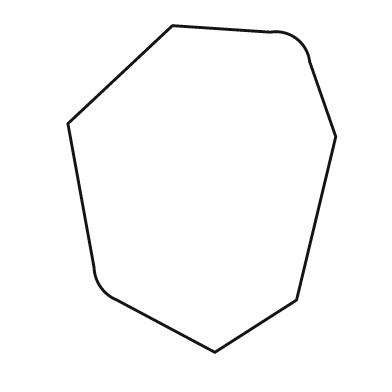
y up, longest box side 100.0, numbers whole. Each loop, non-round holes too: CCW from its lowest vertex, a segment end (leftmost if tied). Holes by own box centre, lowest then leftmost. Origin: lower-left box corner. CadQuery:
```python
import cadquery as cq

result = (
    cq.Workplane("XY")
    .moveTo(45.0, 0.0)
    .lineTo(70.0, 16.0)
    .lineTo(82.0, 66.0)
    .lineTo(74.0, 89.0)
    .threePointArc((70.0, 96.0), (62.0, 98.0))
    .lineTo(32.0, 100.0)
    .lineTo(0.0, 70.0)
    .lineTo(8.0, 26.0)
    .threePointArc((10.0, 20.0), (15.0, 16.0))
    .close()
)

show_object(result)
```